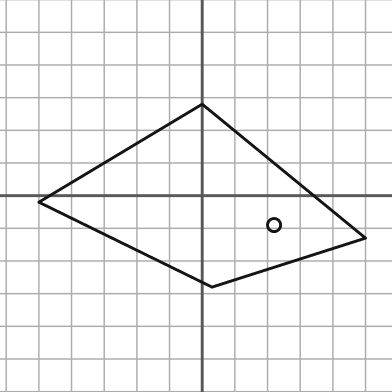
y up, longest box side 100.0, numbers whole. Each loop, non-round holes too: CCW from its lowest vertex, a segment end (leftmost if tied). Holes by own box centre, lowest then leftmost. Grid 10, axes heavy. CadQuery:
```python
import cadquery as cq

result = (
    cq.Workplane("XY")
    .moveTo(3.0, -28.0)
    .lineTo(50.0, -13.0)
    .lineTo(0.0, 28.0)
    .lineTo(-50.0, -2.0)
    .close()
    .moveTo(22.0, -9.0)
    .circle(2.0)
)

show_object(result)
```